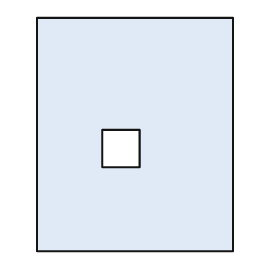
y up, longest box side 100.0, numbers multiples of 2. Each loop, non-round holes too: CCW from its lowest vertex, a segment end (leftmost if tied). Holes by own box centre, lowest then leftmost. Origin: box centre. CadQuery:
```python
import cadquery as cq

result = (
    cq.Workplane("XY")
    .moveTo(-42.0, -50.0)
    .lineTo(42.0, -50.0)
    .lineTo(42.0, 50.0)
    .lineTo(-42.0, 50.0)
    .close()
    .moveTo(-14.0, -14.0)
    .lineTo(2.0, -14.0)
    .lineTo(2.0, 2.0)
    .lineTo(-14.0, 2.0)
    .close()
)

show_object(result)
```